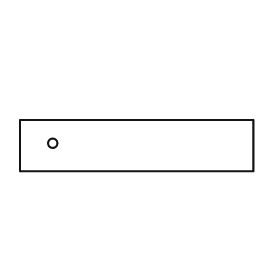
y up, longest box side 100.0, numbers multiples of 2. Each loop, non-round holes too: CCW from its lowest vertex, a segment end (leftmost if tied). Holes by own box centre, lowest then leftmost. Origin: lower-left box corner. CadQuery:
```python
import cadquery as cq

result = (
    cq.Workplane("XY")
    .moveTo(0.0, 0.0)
    .lineTo(100.0, 0.0)
    .lineTo(100.0, 22.0)
    .lineTo(0.0, 22.0)
    .close()
    .moveTo(14.0, 12.0)
    .circle(2.0)
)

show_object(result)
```